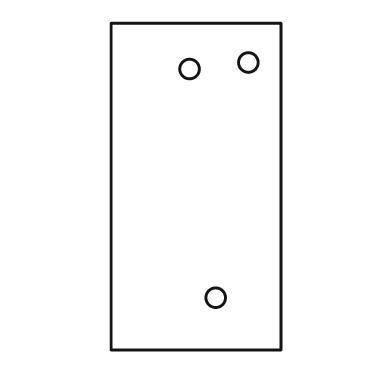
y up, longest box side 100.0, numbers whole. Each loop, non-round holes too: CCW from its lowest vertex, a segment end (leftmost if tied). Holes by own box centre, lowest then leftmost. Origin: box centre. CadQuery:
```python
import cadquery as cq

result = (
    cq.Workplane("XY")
    .moveTo(-26.0, -50.0)
    .lineTo(26.0, -50.0)
    .lineTo(26.0, 50.0)
    .lineTo(-26.0, 50.0)
    .close()
    .moveTo(6.0, -34.0)
    .circle(3.0)
    .moveTo(-2.0, 36.0)
    .circle(3.0)
    .moveTo(16.0, 38.0)
    .circle(3.0)
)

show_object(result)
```